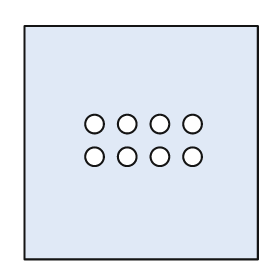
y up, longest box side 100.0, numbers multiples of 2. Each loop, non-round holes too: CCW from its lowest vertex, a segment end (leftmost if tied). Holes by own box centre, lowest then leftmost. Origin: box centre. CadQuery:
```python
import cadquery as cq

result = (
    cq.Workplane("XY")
    .moveTo(-50.0, -50.0)
    .lineTo(50.0, -50.0)
    .lineTo(50.0, 50.0)
    .lineTo(-50.0, 50.0)
    .close()
    .moveTo(-20.0, -6.0)
    .circle(4.0)
    .moveTo(-6.0, -6.0)
    .circle(4.0)
    .moveTo(8.0, -6.0)
    .circle(4.0)
    .moveTo(22.0, -6.0)
    .circle(4.0)
    .moveTo(-20.0, 8.0)
    .circle(4.0)
    .moveTo(-6.0, 8.0)
    .circle(4.0)
    .moveTo(8.0, 8.0)
    .circle(4.0)
    .moveTo(22.0, 8.0)
    .circle(4.0)
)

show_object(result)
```